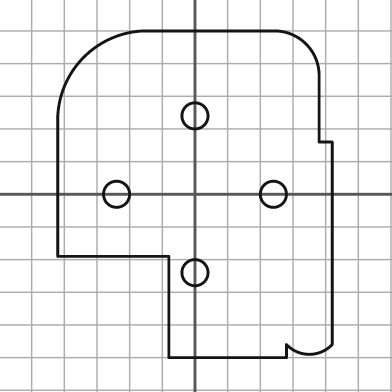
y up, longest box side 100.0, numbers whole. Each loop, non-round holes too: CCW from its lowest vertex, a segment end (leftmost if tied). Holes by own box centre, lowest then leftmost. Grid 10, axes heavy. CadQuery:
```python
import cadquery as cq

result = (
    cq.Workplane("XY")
    .moveTo(-8.0, -50.0)
    .lineTo(28.0, -50.0)
    .lineTo(28.0, -46.0)
    .threePointArc((35.0, -49.0), (42.0, -46.0))
    .lineTo(42.0, 16.0)
    .lineTo(38.0, 16.0)
    .lineTo(38.0, 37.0)
    .threePointArc((34.0, 46.0), (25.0, 50.0))
    .lineTo(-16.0, 50.0)
    .threePointArc((-34.0, 42.0), (-42.0, 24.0))
    .lineTo(-42.0, -19.0)
    .lineTo(-8.0, -19.0)
    .close()
    .moveTo(0.0, -24.0)
    .circle(4.0)
    .moveTo(-24.0, 0.0)
    .circle(4.0)
    .moveTo(24.0, 0.0)
    .circle(4.0)
    .moveTo(0.0, 24.0)
    .circle(4.0)
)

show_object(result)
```